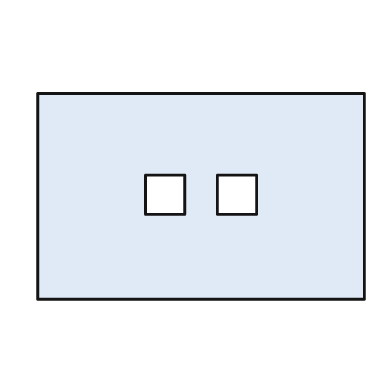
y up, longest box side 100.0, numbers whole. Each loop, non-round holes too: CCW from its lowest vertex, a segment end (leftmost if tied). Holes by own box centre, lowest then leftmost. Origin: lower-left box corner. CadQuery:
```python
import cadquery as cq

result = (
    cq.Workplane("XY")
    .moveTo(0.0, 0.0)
    .lineTo(100.0, 0.0)
    .lineTo(100.0, 63.0)
    .lineTo(0.0, 63.0)
    .close()
    .moveTo(33.0, 26.0)
    .lineTo(45.0, 26.0)
    .lineTo(45.0, 38.0)
    .lineTo(33.0, 38.0)
    .close()
    .moveTo(55.0, 26.0)
    .lineTo(67.0, 26.0)
    .lineTo(67.0, 38.0)
    .lineTo(55.0, 38.0)
    .close()
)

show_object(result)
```